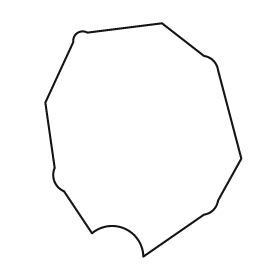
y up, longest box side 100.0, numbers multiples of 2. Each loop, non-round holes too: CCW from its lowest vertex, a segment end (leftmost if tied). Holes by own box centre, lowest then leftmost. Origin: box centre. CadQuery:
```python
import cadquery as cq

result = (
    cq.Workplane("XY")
    .moveTo(0.0, -50.0)
    .lineTo(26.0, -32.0)
    .threePointArc((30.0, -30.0), (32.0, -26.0))
    .lineTo(42.0, -8.0)
    .lineTo(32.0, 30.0)
    .threePointArc((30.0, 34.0), (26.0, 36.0))
    .lineTo(8.0, 50.0)
    .lineTo(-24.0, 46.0)
    .threePointArc((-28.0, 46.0), (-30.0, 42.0))
    .lineTo(-42.0, 16.0)
    .lineTo(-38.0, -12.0)
    .threePointArc((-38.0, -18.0), (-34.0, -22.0))
    .lineTo(-22.0, -40.0)
    .threePointArc((-8.0, -38.0), (0.0, -50.0))
    .close()
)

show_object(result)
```